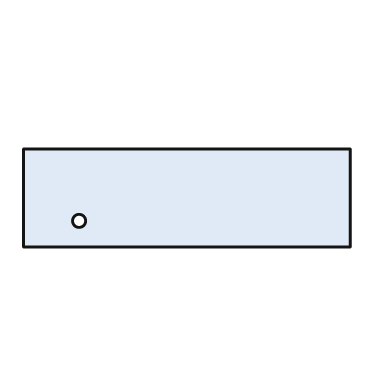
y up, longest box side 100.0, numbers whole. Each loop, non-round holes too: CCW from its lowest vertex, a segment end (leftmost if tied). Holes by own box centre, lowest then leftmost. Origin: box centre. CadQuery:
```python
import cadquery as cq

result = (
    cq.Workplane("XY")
    .moveTo(-50.0, -15.0)
    .lineTo(50.0, -15.0)
    .lineTo(50.0, 15.0)
    .lineTo(-50.0, 15.0)
    .close()
    .moveTo(-33.0, -7.0)
    .circle(2.0)
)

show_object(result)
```